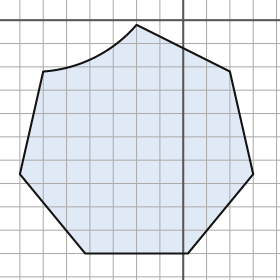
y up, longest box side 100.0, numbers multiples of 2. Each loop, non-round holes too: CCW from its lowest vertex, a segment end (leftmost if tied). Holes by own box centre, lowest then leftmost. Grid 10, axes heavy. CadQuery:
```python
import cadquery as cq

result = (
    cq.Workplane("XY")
    .moveTo(-42.0, -100.0)
    .lineTo(2.0, -100.0)
    .lineTo(30.0, -66.0)
    .lineTo(20.0, -22.0)
    .lineTo(-20.0, -2.0)
    .threePointArc((-38.0, -16.0), (-60.0, -22.0))
    .lineTo(-70.0, -66.0)
    .close()
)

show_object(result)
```